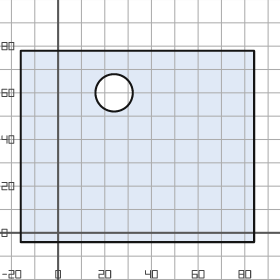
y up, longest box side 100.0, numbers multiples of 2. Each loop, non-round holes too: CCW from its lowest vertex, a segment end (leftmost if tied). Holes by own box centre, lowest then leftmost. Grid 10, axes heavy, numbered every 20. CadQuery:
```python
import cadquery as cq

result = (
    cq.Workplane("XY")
    .moveTo(-16.0, -4.0)
    .lineTo(84.0, -4.0)
    .lineTo(84.0, 78.0)
    .lineTo(-16.0, 78.0)
    .close()
    .moveTo(24.0, 60.0)
    .circle(8.0)
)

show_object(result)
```